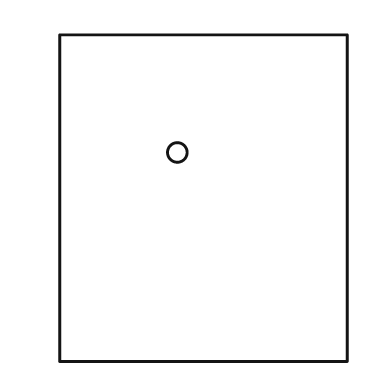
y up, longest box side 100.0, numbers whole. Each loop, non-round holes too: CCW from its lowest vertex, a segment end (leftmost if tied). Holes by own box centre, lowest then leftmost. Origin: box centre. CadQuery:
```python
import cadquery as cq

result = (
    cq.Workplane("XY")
    .moveTo(-44.0, -50.0)
    .lineTo(44.0, -50.0)
    .lineTo(44.0, 50.0)
    .lineTo(-44.0, 50.0)
    .close()
    .moveTo(-8.0, 14.0)
    .circle(3.0)
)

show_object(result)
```